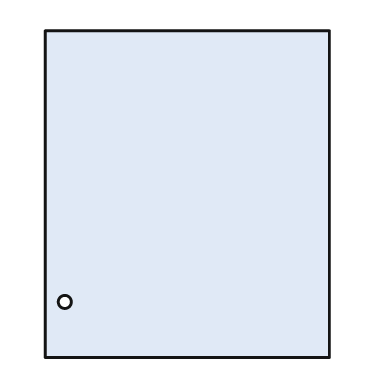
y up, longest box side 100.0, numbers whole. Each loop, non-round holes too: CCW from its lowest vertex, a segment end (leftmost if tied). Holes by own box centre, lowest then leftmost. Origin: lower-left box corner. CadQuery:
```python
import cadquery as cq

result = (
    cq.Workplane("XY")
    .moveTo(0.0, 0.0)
    .lineTo(87.0, 0.0)
    .lineTo(87.0, 100.0)
    .lineTo(0.0, 100.0)
    .close()
    .moveTo(6.0, 17.0)
    .circle(2.0)
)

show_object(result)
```